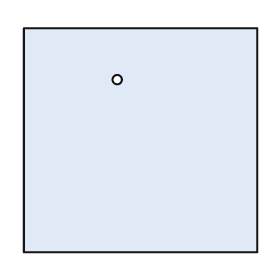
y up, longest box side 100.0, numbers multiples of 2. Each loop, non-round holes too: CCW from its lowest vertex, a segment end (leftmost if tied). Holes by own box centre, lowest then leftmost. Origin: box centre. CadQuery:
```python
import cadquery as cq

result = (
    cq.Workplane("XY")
    .moveTo(-50.0, -48.0)
    .lineTo(50.0, -48.0)
    .lineTo(50.0, 48.0)
    .lineTo(-50.0, 48.0)
    .close()
    .moveTo(-10.0, 26.0)
    .circle(2.0)
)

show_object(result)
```